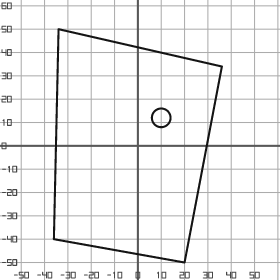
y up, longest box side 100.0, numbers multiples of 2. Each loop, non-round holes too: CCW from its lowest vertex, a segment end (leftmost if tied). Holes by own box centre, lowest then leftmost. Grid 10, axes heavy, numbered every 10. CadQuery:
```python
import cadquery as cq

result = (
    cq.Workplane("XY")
    .moveTo(20.0, -50.0)
    .lineTo(36.0, 34.0)
    .lineTo(-34.0, 50.0)
    .lineTo(-36.0, -40.0)
    .close()
    .moveTo(10.0, 12.0)
    .circle(4.0)
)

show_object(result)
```